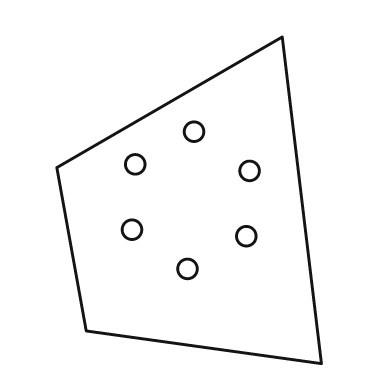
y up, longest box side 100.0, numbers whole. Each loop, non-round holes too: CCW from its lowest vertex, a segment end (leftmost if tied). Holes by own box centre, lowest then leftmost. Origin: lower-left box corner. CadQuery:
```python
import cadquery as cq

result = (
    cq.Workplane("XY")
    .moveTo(81.0, 0.0)
    .lineTo(69.0, 100.0)
    .lineTo(0.0, 60.0)
    .lineTo(9.0, 10.0)
    .close()
    .moveTo(40.0, 29.0)
    .circle(3.0)
    .moveTo(58.0, 39.0)
    .circle(3.0)
    .moveTo(23.0, 41.0)
    .circle(3.0)
    .moveTo(59.0, 59.0)
    .circle(3.0)
    .moveTo(24.0, 61.0)
    .circle(3.0)
    .moveTo(42.0, 71.0)
    .circle(3.0)
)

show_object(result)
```